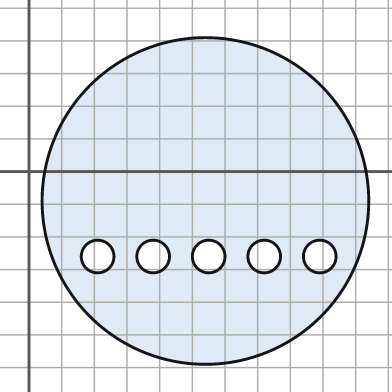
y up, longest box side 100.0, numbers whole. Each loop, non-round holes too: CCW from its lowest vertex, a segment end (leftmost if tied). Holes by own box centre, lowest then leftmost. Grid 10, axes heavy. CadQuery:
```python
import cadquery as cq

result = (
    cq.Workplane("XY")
    .moveTo(54.0, -9.0)
    .circle(50.0)
    .moveTo(21.0, -26.0)
    .circle(5.0)
    .moveTo(38.0, -26.0)
    .circle(5.0)
    .moveTo(55.0, -26.0)
    .circle(5.0)
    .moveTo(72.0, -26.0)
    .circle(5.0)
    .moveTo(89.0, -26.0)
    .circle(5.0)
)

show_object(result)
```